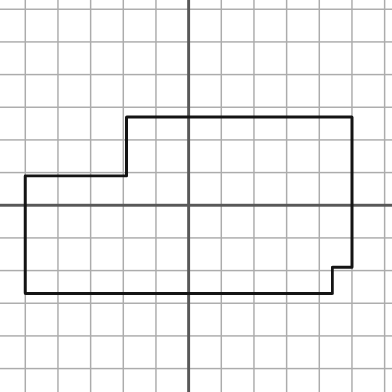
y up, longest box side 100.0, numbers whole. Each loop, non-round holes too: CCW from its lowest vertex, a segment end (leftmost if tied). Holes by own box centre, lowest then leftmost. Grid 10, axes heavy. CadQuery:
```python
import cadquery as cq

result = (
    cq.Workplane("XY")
    .moveTo(-50.0, -27.0)
    .lineTo(44.0, -27.0)
    .lineTo(44.0, -19.0)
    .lineTo(50.0, -19.0)
    .lineTo(50.0, 27.0)
    .lineTo(-19.0, 27.0)
    .lineTo(-19.0, 9.0)
    .lineTo(-50.0, 9.0)
    .close()
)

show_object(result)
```